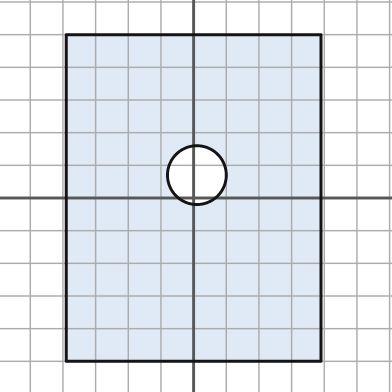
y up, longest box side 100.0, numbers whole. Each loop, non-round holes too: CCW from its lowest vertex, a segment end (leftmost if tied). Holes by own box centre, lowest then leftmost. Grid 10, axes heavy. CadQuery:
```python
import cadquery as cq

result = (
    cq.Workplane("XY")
    .moveTo(-39.0, -50.0)
    .lineTo(39.0, -50.0)
    .lineTo(39.0, 50.0)
    .lineTo(-39.0, 50.0)
    .close()
    .moveTo(1.0, 7.0)
    .circle(9.0)
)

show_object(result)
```